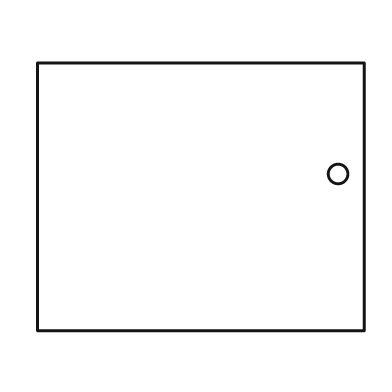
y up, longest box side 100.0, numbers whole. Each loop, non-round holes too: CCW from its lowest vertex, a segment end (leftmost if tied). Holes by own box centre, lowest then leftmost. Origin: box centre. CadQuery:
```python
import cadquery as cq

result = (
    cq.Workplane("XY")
    .moveTo(-50.0, -41.0)
    .lineTo(50.0, -41.0)
    .lineTo(50.0, 41.0)
    .lineTo(-50.0, 41.0)
    .close()
    .moveTo(42.0, 7.0)
    .circle(3.0)
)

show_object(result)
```